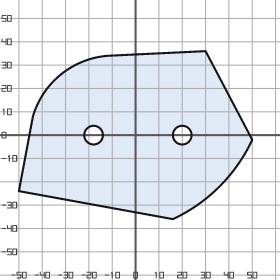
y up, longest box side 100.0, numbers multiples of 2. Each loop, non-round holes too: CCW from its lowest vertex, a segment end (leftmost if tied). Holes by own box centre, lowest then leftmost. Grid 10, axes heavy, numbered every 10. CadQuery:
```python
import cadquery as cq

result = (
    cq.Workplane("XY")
    .moveTo(16.0, -36.0)
    .threePointArc((36.0, -22.0), (50.0, -2.0))
    .lineTo(30.0, 36.0)
    .lineTo(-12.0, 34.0)
    .threePointArc((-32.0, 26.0), (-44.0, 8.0))
    .lineTo(-50.0, -24.0)
    .close()
    .moveTo(-18.0, 0.0)
    .circle(4.0)
    .moveTo(20.0, 0.0)
    .circle(4.0)
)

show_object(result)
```